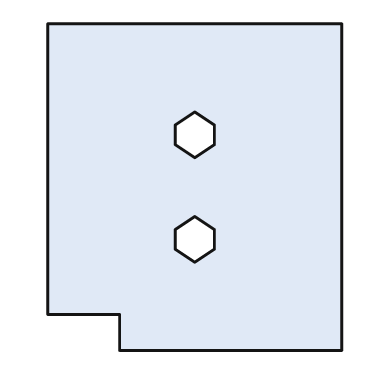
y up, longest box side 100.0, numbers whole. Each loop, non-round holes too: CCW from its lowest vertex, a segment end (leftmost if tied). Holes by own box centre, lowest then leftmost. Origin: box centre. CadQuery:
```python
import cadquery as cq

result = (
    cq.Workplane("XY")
    .moveTo(-23.0, -50.0)
    .lineTo(45.0, -50.0)
    .lineTo(45.0, 50.0)
    .lineTo(-45.0, 50.0)
    .lineTo(-45.0, -39.0)
    .lineTo(-23.0, -39.0)
    .close()
    .moveTo(0.0, -23.0)
    .lineTo(6.0, -19.0)
    .lineTo(6.0, -13.0)
    .lineTo(0.0, -9.0)
    .lineTo(-6.0, -13.0)
    .lineTo(-6.0, -19.0)
    .close()
    .moveTo(0.0, 9.0)
    .lineTo(6.0, 13.0)
    .lineTo(6.0, 19.0)
    .lineTo(0.0, 23.0)
    .lineTo(-6.0, 19.0)
    .lineTo(-6.0, 13.0)
    .close()
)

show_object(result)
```